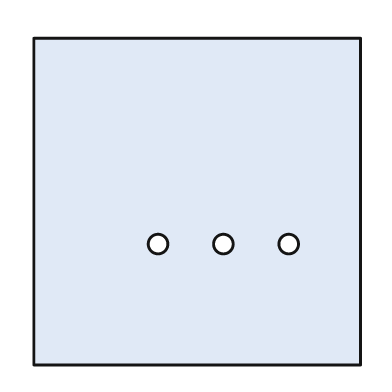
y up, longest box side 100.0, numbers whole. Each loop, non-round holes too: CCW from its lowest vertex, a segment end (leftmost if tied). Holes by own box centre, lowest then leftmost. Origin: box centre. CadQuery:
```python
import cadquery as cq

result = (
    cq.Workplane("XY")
    .moveTo(-50.0, -50.0)
    .lineTo(50.0, -50.0)
    .lineTo(50.0, 50.0)
    .lineTo(-50.0, 50.0)
    .close()
    .moveTo(-12.0, -13.0)
    .circle(3.0)
    .moveTo(8.0, -13.0)
    .circle(3.0)
    .moveTo(28.0, -13.0)
    .circle(3.0)
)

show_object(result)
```